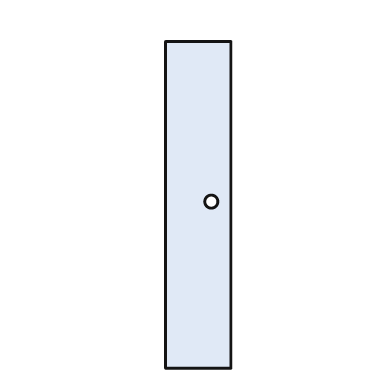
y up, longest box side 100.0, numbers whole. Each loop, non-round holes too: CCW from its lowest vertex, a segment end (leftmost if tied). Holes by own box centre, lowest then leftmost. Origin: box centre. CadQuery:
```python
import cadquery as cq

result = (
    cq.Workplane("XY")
    .moveTo(-10.0, -50.0)
    .lineTo(10.0, -50.0)
    .lineTo(10.0, 50.0)
    .lineTo(-10.0, 50.0)
    .close()
    .moveTo(4.0, 1.0)
    .circle(2.0)
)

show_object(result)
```